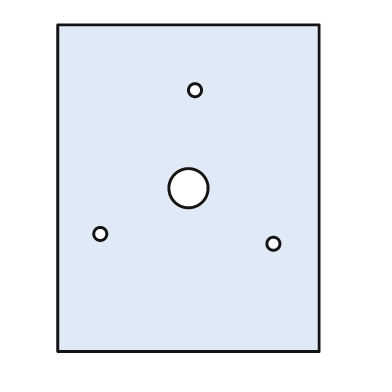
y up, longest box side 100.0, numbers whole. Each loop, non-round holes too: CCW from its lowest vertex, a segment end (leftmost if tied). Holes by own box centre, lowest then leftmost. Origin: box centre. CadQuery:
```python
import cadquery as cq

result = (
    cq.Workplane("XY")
    .moveTo(-40.0, -50.0)
    .lineTo(40.0, -50.0)
    .lineTo(40.0, 50.0)
    .lineTo(-40.0, 50.0)
    .close()
    .moveTo(26.0, -17.0)
    .circle(2.0)
    .moveTo(-27.0, -14.0)
    .circle(2.0)
    .moveTo(0.0, 0.0)
    .circle(6.0)
    .moveTo(2.0, 30.0)
    .circle(2.0)
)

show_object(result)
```